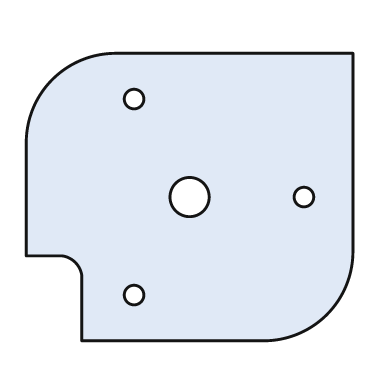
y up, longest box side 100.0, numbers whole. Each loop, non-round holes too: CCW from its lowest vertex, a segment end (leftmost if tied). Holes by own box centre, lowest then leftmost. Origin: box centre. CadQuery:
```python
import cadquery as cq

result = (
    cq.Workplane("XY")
    .moveTo(-33.0, -44.0)
    .lineTo(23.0, -44.0)
    .threePointArc((42.0, -36.0), (50.0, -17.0))
    .lineTo(50.0, 44.0)
    .lineTo(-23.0, 44.0)
    .threePointArc((-42.0, 36.0), (-50.0, 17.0))
    .lineTo(-50.0, -18.0)
    .lineTo(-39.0, -18.0)
    .threePointArc((-35.0, -20.0), (-33.0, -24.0))
    .close()
    .moveTo(-17.0, -30.0)
    .circle(3.0)
    .moveTo(0.0, 0.0)
    .circle(6.0)
    .moveTo(35.0, 0.0)
    .circle(3.0)
    .moveTo(-17.0, 30.0)
    .circle(3.0)
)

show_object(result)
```